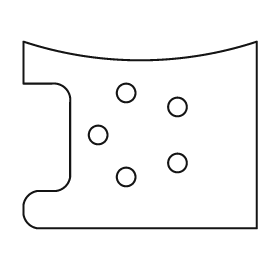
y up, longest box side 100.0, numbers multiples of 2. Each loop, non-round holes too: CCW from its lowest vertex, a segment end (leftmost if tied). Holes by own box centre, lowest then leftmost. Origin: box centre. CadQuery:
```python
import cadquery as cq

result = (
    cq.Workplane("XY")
    .moveTo(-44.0, -40.0)
    .lineTo(50.0, -40.0)
    .lineTo(50.0, 40.0)
    .threePointArc((0.0, 32.0), (-50.0, 40.0))
    .lineTo(-50.0, 22.0)
    .lineTo(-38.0, 22.0)
    .threePointArc((-32.0, 20.0), (-30.0, 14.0))
    .lineTo(-30.0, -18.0)
    .threePointArc((-32.0, -22.0), (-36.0, -24.0))
    .lineTo(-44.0, -24.0)
    .threePointArc((-48.0, -26.0), (-50.0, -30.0))
    .lineTo(-50.0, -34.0)
    .threePointArc((-48.0, -38.0), (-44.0, -40.0))
    .close()
    .moveTo(-6.0, -18.0)
    .circle(4.0)
    .moveTo(16.0, -12.0)
    .circle(4.0)
    .moveTo(-18.0, 0.0)
    .circle(4.0)
    .moveTo(16.0, 12.0)
    .circle(4.0)
    .moveTo(-6.0, 18.0)
    .circle(4.0)
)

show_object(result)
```